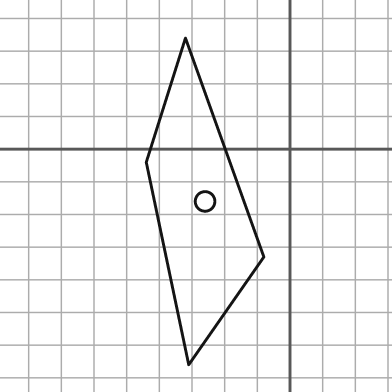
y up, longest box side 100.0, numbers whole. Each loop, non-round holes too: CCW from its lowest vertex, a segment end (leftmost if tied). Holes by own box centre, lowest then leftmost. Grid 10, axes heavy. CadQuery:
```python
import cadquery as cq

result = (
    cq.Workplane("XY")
    .moveTo(-31.0, -66.0)
    .lineTo(-8.0, -33.0)
    .lineTo(-32.0, 34.0)
    .lineTo(-44.0, -4.0)
    .close()
    .moveTo(-26.0, -16.0)
    .circle(3.0)
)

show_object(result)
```